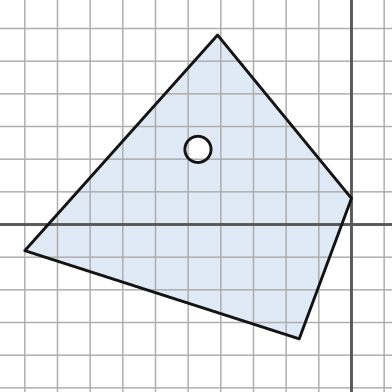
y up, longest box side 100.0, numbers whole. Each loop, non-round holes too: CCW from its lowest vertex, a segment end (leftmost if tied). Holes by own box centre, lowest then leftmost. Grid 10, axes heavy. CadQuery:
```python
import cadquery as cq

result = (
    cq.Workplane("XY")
    .moveTo(-16.0, -35.0)
    .lineTo(0.0, 8.0)
    .lineTo(-41.0, 58.0)
    .lineTo(-100.0, -8.0)
    .close()
    .moveTo(-47.0, 23.0)
    .circle(4.0)
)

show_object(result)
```